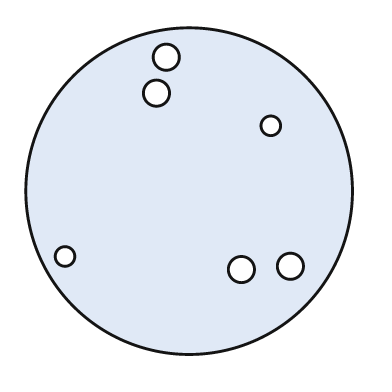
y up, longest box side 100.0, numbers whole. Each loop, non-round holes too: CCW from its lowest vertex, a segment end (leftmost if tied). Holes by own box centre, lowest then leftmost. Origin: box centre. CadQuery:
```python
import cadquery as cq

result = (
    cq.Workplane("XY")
    .moveTo(0.0, 0.0)
    .circle(50.0)
    .moveTo(16.0, -24.0)
    .circle(4.0)
    .moveTo(31.0, -23.0)
    .circle(4.0)
    .moveTo(-38.0, -20.0)
    .circle(3.0)
    .moveTo(25.0, 20.0)
    .circle(3.0)
    .moveTo(-10.0, 30.0)
    .circle(4.0)
    .moveTo(-7.0, 41.0)
    .circle(4.0)
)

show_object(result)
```